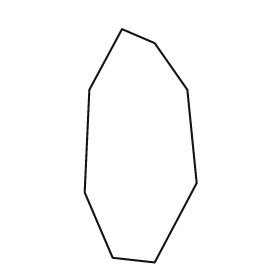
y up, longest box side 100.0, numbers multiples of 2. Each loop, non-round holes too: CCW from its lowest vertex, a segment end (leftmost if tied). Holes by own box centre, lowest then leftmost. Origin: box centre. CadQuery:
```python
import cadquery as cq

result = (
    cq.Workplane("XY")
    .moveTo(6.0, -50.0)
    .lineTo(24.0, -16.0)
    .lineTo(20.0, 24.0)
    .lineTo(6.0, 44.0)
    .lineTo(-8.0, 50.0)
    .lineTo(-22.0, 24.0)
    .lineTo(-24.0, -20.0)
    .lineTo(-12.0, -48.0)
    .close()
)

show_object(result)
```